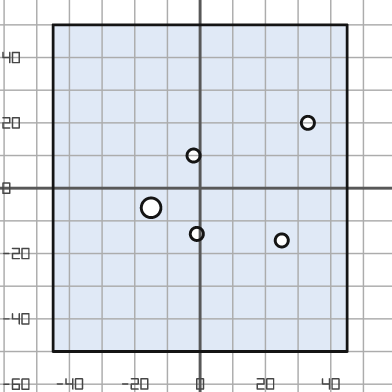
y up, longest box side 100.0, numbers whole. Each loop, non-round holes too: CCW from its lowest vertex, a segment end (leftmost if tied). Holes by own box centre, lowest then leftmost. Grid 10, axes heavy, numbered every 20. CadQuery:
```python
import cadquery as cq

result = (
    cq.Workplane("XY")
    .moveTo(-45.0, -50.0)
    .lineTo(45.0, -50.0)
    .lineTo(45.0, 50.0)
    .lineTo(-45.0, 50.0)
    .close()
    .moveTo(25.0, -16.0)
    .circle(2.0)
    .moveTo(-1.0, -14.0)
    .circle(2.0)
    .moveTo(-15.0, -6.0)
    .circle(3.0)
    .moveTo(-2.0, 10.0)
    .circle(2.0)
    .moveTo(33.0, 20.0)
    .circle(2.0)
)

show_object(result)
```